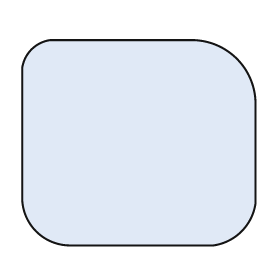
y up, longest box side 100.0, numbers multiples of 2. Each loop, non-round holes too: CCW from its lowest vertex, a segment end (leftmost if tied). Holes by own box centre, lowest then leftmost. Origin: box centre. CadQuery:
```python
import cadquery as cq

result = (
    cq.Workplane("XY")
    .moveTo(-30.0, -44.0)
    .lineTo(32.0, -44.0)
    .threePointArc((44.0, -38.0), (50.0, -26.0))
    .lineTo(50.0, 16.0)
    .threePointArc((42.0, 36.0), (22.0, 44.0))
    .lineTo(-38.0, 44.0)
    .threePointArc((-46.0, 40.0), (-50.0, 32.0))
    .lineTo(-50.0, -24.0)
    .threePointArc((-44.0, -38.0), (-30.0, -44.0))
    .close()
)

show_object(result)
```